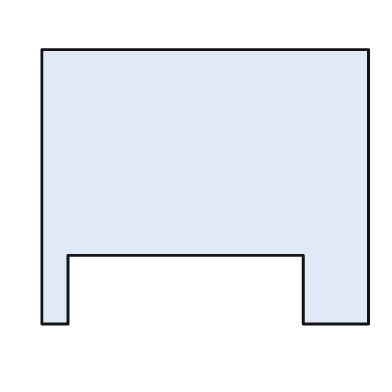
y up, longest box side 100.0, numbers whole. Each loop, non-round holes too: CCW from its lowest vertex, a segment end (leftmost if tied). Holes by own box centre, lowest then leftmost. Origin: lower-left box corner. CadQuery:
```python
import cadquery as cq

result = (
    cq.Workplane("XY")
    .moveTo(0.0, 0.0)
    .lineTo(8.0, 0.0)
    .lineTo(8.0, 21.0)
    .lineTo(80.0, 21.0)
    .lineTo(80.0, 0.0)
    .lineTo(100.0, 0.0)
    .lineTo(100.0, 84.0)
    .lineTo(0.0, 84.0)
    .close()
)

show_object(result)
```